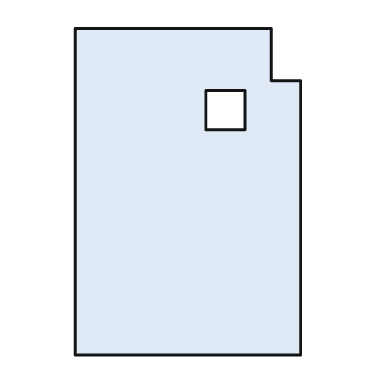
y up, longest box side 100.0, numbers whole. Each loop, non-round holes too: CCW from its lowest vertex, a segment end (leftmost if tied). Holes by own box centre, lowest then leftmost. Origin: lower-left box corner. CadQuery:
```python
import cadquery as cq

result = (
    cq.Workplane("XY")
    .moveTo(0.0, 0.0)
    .lineTo(69.0, 0.0)
    .lineTo(69.0, 84.0)
    .lineTo(60.0, 84.0)
    .lineTo(60.0, 100.0)
    .lineTo(0.0, 100.0)
    .close()
    .moveTo(40.0, 69.0)
    .lineTo(52.0, 69.0)
    .lineTo(52.0, 81.0)
    .lineTo(40.0, 81.0)
    .close()
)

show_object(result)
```